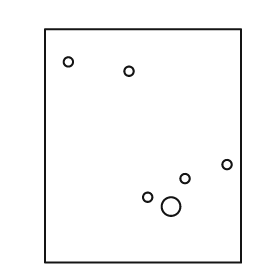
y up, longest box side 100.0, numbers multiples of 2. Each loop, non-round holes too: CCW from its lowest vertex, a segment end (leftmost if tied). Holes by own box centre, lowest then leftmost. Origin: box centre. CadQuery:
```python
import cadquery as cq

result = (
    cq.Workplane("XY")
    .moveTo(-42.0, -50.0)
    .lineTo(42.0, -50.0)
    .lineTo(42.0, 50.0)
    .lineTo(-42.0, 50.0)
    .close()
    .moveTo(12.0, -26.0)
    .circle(4.0)
    .moveTo(2.0, -22.0)
    .circle(2.0)
    .moveTo(18.0, -14.0)
    .circle(2.0)
    .moveTo(36.0, -8.0)
    .circle(2.0)
    .moveTo(-6.0, 32.0)
    .circle(2.0)
    .moveTo(-32.0, 36.0)
    .circle(2.0)
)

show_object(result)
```